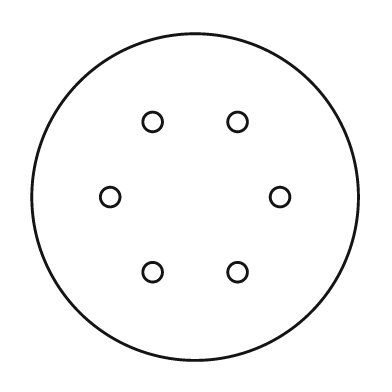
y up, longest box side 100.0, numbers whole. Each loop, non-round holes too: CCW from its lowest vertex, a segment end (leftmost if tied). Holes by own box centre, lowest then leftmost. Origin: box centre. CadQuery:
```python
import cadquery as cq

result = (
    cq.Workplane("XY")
    .moveTo(0.0, 0.0)
    .circle(50.0)
    .moveTo(-13.0, -23.0)
    .circle(3.0)
    .moveTo(13.0, -23.0)
    .circle(3.0)
    .moveTo(-26.0, 0.0)
    .circle(3.0)
    .moveTo(26.0, 0.0)
    .circle(3.0)
    .moveTo(-13.0, 23.0)
    .circle(3.0)
    .moveTo(13.0, 23.0)
    .circle(3.0)
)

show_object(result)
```